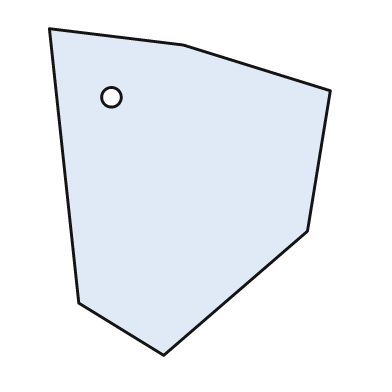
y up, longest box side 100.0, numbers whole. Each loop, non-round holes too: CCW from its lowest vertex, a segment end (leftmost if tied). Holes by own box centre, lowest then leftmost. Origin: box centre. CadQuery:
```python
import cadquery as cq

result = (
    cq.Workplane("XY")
    .moveTo(-8.0, -50.0)
    .lineTo(36.0, -12.0)
    .lineTo(43.0, 31.0)
    .lineTo(-2.0, 45.0)
    .lineTo(-43.0, 50.0)
    .lineTo(-34.0, -34.0)
    .close()
    .moveTo(-24.0, 29.0)
    .circle(3.0)
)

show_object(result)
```